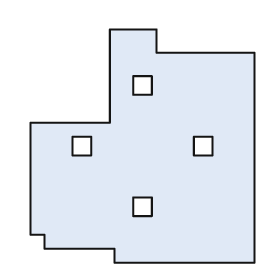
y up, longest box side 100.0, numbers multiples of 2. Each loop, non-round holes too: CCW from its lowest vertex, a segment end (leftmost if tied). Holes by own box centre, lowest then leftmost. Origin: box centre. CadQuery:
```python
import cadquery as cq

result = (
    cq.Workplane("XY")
    .moveTo(-12.0, -50.0)
    .lineTo(48.0, -50.0)
    .lineTo(48.0, 40.0)
    .lineTo(6.0, 40.0)
    .lineTo(6.0, 50.0)
    .lineTo(-14.0, 50.0)
    .lineTo(-14.0, 10.0)
    .lineTo(-48.0, 10.0)
    .lineTo(-48.0, -38.0)
    .lineTo(-42.0, -38.0)
    .lineTo(-42.0, -44.0)
    .lineTo(-12.0, -44.0)
    .close()
    .moveTo(-4.0, -30.0)
    .lineTo(4.0, -30.0)
    .lineTo(4.0, -22.0)
    .lineTo(-4.0, -22.0)
    .close()
    .moveTo(-30.0, -4.0)
    .lineTo(-22.0, -4.0)
    .lineTo(-22.0, 4.0)
    .lineTo(-30.0, 4.0)
    .close()
    .moveTo(22.0, -4.0)
    .lineTo(30.0, -4.0)
    .lineTo(30.0, 4.0)
    .lineTo(22.0, 4.0)
    .close()
    .moveTo(-4.0, 22.0)
    .lineTo(4.0, 22.0)
    .lineTo(4.0, 30.0)
    .lineTo(-4.0, 30.0)
    .close()
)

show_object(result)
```